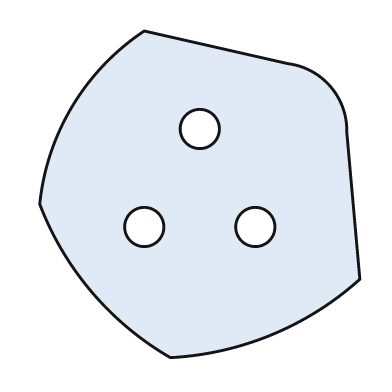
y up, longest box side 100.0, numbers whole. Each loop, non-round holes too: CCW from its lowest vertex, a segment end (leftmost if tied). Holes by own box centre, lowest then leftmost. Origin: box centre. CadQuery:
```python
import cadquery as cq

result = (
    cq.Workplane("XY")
    .moveTo(-9.0, -50.0)
    .threePointArc((22.0, -43.0), (49.0, -26.0))
    .lineTo(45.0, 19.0)
    .threePointArc((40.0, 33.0), (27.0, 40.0))
    .lineTo(-17.0, 50.0)
    .threePointArc((-39.0, 27.0), (-49.0, -3.0))
    .threePointArc((-33.0, -30.0), (-9.0, -50.0))
    .close()
    .moveTo(-17.0, -10.0)
    .circle(6.0)
    .moveTo(17.0, -10.0)
    .circle(6.0)
    .moveTo(0.0, 20.0)
    .circle(6.0)
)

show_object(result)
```